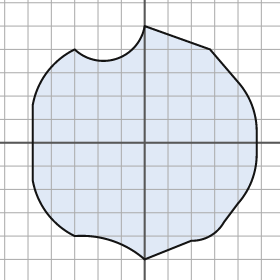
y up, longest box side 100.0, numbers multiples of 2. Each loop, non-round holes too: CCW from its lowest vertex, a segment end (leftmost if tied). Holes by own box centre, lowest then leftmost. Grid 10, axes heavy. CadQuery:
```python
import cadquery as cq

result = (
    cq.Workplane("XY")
    .moveTo(0.0, -50.0)
    .lineTo(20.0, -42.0)
    .threePointArc((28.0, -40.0), (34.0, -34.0))
    .lineTo(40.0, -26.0)
    .threePointArc((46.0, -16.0), (48.0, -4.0))
    .lineTo(48.0, 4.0)
    .threePointArc((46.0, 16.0), (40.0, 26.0))
    .lineTo(28.0, 40.0)
    .lineTo(0.0, 50.0)
    .threePointArc((-12.0, 36.0), (-30.0, 40.0))
    .threePointArc((-42.0, 30.0), (-48.0, 16.0))
    .lineTo(-48.0, -16.0)
    .threePointArc((-42.0, -30.0), (-30.0, -40.0))
    .threePointArc((-14.0, -42.0), (0.0, -50.0))
    .close()
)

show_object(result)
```